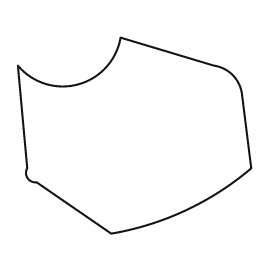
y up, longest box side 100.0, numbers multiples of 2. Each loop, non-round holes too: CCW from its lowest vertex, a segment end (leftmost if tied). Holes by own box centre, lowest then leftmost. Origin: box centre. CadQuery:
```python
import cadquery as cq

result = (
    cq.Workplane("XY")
    .moveTo(-10.0, -42.0)
    .threePointArc((22.0, -32.0), (50.0, -14.0))
    .lineTo(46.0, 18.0)
    .threePointArc((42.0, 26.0), (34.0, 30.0))
    .lineTo(-6.0, 42.0)
    .threePointArc((-24.0, 22.0), (-50.0, 30.0))
    .lineTo(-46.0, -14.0)
    .threePointArc((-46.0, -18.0), (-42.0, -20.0))
    .close()
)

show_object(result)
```